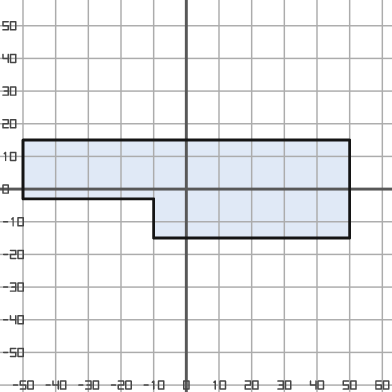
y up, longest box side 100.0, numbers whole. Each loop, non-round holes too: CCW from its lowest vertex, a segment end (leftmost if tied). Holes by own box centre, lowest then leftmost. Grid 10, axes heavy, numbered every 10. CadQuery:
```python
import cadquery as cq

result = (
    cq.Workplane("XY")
    .moveTo(-10.0, -15.0)
    .lineTo(50.0, -15.0)
    .lineTo(50.0, 15.0)
    .lineTo(-50.0, 15.0)
    .lineTo(-50.0, -3.0)
    .lineTo(-10.0, -3.0)
    .close()
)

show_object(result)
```